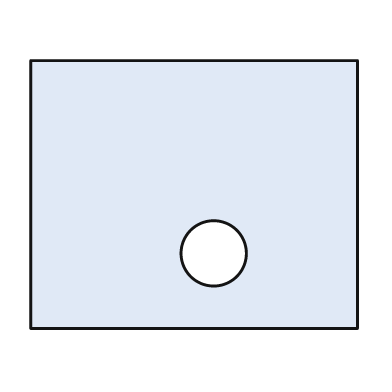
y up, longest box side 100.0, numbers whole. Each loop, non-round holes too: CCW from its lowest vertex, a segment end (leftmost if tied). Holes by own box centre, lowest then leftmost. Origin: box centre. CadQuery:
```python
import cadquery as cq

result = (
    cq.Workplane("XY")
    .moveTo(-50.0, -41.0)
    .lineTo(50.0, -41.0)
    .lineTo(50.0, 41.0)
    .lineTo(-50.0, 41.0)
    .close()
    .moveTo(6.0, -18.0)
    .circle(10.0)
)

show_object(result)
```